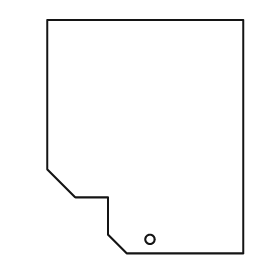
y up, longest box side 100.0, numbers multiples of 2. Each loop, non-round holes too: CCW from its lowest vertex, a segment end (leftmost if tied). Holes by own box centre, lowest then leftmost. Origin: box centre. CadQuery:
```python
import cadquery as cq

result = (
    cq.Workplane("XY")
    .moveTo(-8.0, -50.0)
    .lineTo(42.0, -50.0)
    .lineTo(42.0, 50.0)
    .lineTo(-42.0, 50.0)
    .lineTo(-42.0, -14.0)
    .lineTo(-30.0, -26.0)
    .lineTo(-16.0, -26.0)
    .lineTo(-16.0, -42.0)
    .close()
    .moveTo(2.0, -44.0)
    .circle(2.0)
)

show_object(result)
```